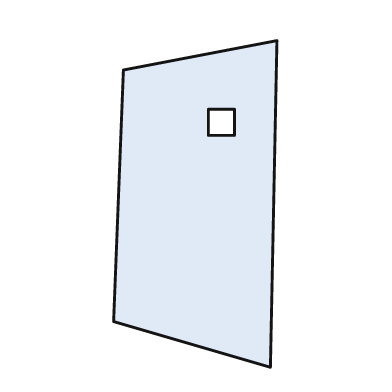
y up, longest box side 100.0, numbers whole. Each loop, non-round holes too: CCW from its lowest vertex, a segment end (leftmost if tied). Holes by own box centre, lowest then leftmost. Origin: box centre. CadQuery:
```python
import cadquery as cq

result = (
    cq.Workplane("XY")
    .moveTo(23.0, -50.0)
    .lineTo(25.0, 50.0)
    .lineTo(-22.0, 41.0)
    .lineTo(-25.0, -36.0)
    .close()
    .moveTo(4.0, 21.0)
    .lineTo(12.0, 21.0)
    .lineTo(12.0, 29.0)
    .lineTo(4.0, 29.0)
    .close()
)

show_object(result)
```